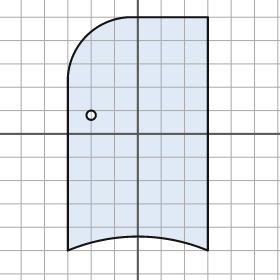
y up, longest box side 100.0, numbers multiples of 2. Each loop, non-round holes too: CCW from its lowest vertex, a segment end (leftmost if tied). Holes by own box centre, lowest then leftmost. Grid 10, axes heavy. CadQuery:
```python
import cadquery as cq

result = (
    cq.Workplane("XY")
    .moveTo(-30.0, -50.0)
    .threePointArc((0.0, -44.0), (30.0, -50.0))
    .lineTo(30.0, 50.0)
    .lineTo(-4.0, 50.0)
    .threePointArc((-22.0, 42.0), (-30.0, 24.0))
    .close()
    .moveTo(-20.0, 8.0)
    .circle(2.0)
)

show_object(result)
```